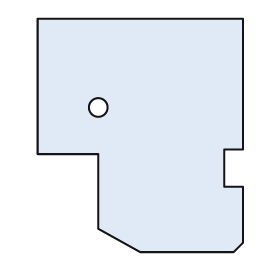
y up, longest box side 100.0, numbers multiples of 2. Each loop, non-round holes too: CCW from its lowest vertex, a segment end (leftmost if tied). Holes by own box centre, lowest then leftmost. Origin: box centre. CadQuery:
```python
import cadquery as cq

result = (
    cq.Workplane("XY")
    .moveTo(0.0, -50.0)
    .lineTo(40.0, -50.0)
    .lineTo(44.0, -46.0)
    .lineTo(44.0, -22.0)
    .lineTo(36.0, -22.0)
    .lineTo(36.0, -6.0)
    .lineTo(44.0, -6.0)
    .lineTo(44.0, 50.0)
    .lineTo(-44.0, 50.0)
    .lineTo(-44.0, -8.0)
    .lineTo(-18.0, -8.0)
    .lineTo(-18.0, -40.0)
    .close()
    .moveTo(-18.0, 12.0)
    .circle(4.0)
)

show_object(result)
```